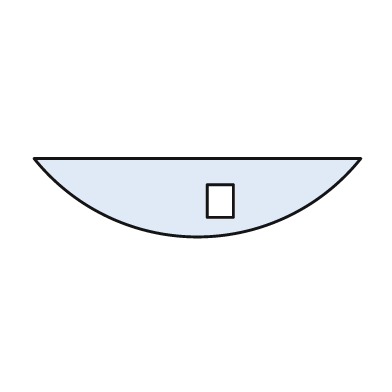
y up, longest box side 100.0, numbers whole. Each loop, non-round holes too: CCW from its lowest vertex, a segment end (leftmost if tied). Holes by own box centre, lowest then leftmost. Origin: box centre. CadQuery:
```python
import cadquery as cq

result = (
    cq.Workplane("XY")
    .moveTo(-50.0, 12.0)
    .threePointArc((0.0, -12.0), (50.0, 12.0))
    .close()
    .moveTo(3.0, -6.0)
    .lineTo(11.0, -6.0)
    .lineTo(11.0, 4.0)
    .lineTo(3.0, 4.0)
    .close()
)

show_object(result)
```